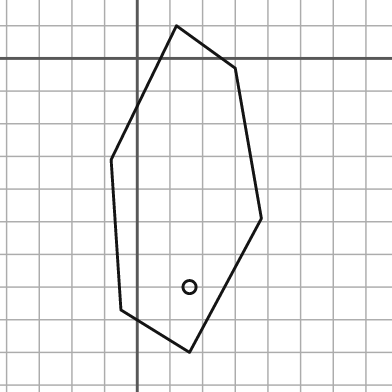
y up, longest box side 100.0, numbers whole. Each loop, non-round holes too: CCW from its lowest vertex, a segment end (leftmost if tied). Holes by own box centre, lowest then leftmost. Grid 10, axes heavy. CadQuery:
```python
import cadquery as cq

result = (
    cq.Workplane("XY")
    .moveTo(16.0, -90.0)
    .lineTo(38.0, -49.0)
    .lineTo(30.0, -3.0)
    .lineTo(12.0, 10.0)
    .lineTo(-8.0, -31.0)
    .lineTo(-5.0, -77.0)
    .close()
    .moveTo(16.0, -70.0)
    .circle(2.0)
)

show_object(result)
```